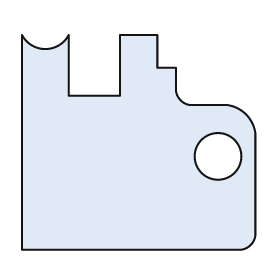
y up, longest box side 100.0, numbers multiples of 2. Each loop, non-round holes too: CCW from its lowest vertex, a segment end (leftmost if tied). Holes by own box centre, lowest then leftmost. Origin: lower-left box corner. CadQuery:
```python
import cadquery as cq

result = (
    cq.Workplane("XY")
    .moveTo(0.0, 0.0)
    .lineTo(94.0, 0.0)
    .threePointArc((98.0, 2.0), (100.0, 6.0))
    .lineTo(100.0, 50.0)
    .threePointArc((96.0, 58.0), (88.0, 62.0))
    .lineTo(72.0, 62.0)
    .threePointArc((68.0, 64.0), (66.0, 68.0))
    .lineTo(66.0, 78.0)
    .lineTo(58.0, 78.0)
    .lineTo(58.0, 92.0)
    .lineTo(42.0, 92.0)
    .lineTo(42.0, 66.0)
    .lineTo(20.0, 66.0)
    .lineTo(20.0, 92.0)
    .threePointArc((10.0, 86.0), (0.0, 92.0))
    .close()
    .moveTo(84.0, 40.0)
    .circle(10.0)
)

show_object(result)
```